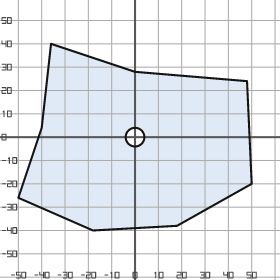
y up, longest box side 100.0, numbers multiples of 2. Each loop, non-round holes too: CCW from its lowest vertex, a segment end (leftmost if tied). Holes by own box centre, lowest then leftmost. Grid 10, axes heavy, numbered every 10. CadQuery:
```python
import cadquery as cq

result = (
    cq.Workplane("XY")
    .moveTo(-18.0, -40.0)
    .lineTo(18.0, -38.0)
    .lineTo(50.0, -20.0)
    .lineTo(48.0, 24.0)
    .lineTo(0.0, 28.0)
    .lineTo(-36.0, 40.0)
    .lineTo(-40.0, 4.0)
    .lineTo(-50.0, -26.0)
    .close()
    .moveTo(0.0, 0.0)
    .circle(4.0)
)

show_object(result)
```